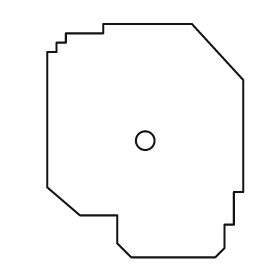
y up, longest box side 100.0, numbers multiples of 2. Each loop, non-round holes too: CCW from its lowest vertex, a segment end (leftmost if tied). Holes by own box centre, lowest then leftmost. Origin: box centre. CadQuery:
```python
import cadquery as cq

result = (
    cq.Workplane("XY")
    .moveTo(-6.0, -50.0)
    .lineTo(30.0, -50.0)
    .lineTo(34.0, -46.0)
    .lineTo(34.0, -36.0)
    .lineTo(38.0, -36.0)
    .lineTo(38.0, -22.0)
    .lineTo(42.0, -22.0)
    .lineTo(42.0, 26.0)
    .lineTo(20.0, 50.0)
    .lineTo(-18.0, 50.0)
    .lineTo(-18.0, 46.0)
    .lineTo(-34.0, 46.0)
    .lineTo(-34.0, 42.0)
    .lineTo(-38.0, 42.0)
    .lineTo(-38.0, 38.0)
    .lineTo(-42.0, 38.0)
    .lineTo(-42.0, -20.0)
    .lineTo(-28.0, -32.0)
    .lineTo(-12.0, -32.0)
    .lineTo(-12.0, -44.0)
    .close()
    .moveTo(0.0, 0.0)
    .circle(4.0)
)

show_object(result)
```